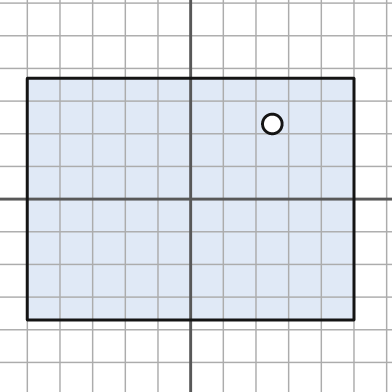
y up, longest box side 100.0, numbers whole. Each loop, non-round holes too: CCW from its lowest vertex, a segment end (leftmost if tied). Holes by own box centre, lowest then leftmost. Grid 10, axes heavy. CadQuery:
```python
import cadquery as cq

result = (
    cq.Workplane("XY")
    .moveTo(-50.0, -37.0)
    .lineTo(50.0, -37.0)
    .lineTo(50.0, 37.0)
    .lineTo(-50.0, 37.0)
    .close()
    .moveTo(25.0, 23.0)
    .circle(3.0)
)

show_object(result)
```